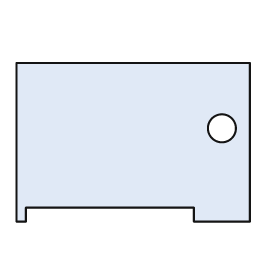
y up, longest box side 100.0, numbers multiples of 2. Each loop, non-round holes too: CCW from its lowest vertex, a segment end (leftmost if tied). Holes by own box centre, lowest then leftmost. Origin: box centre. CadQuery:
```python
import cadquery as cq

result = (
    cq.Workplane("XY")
    .moveTo(-50.0, -34.0)
    .lineTo(-46.0, -34.0)
    .lineTo(-46.0, -28.0)
    .lineTo(26.0, -28.0)
    .lineTo(26.0, -34.0)
    .lineTo(50.0, -34.0)
    .lineTo(50.0, 34.0)
    .lineTo(-50.0, 34.0)
    .close()
    .moveTo(38.0, 6.0)
    .circle(6.0)
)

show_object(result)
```